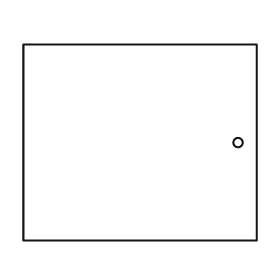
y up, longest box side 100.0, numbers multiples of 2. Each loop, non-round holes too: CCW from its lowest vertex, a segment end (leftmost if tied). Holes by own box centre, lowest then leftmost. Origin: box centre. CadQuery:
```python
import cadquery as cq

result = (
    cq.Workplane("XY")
    .moveTo(-50.0, -42.0)
    .lineTo(50.0, -42.0)
    .lineTo(50.0, 42.0)
    .lineTo(-50.0, 42.0)
    .close()
    .moveTo(42.0, 0.0)
    .circle(2.0)
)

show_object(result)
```